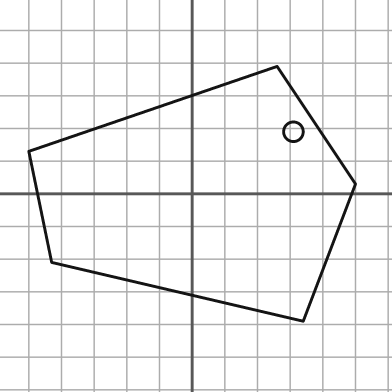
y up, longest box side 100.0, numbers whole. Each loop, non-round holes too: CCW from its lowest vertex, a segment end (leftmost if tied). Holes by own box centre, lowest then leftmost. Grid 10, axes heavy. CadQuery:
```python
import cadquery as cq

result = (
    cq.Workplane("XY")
    .moveTo(34.0, -39.0)
    .lineTo(50.0, 3.0)
    .lineTo(26.0, 39.0)
    .lineTo(-50.0, 13.0)
    .lineTo(-43.0, -21.0)
    .close()
    .moveTo(31.0, 19.0)
    .circle(3.0)
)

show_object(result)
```